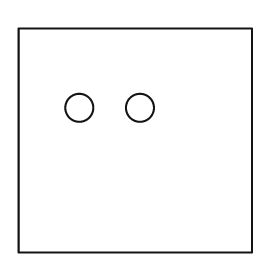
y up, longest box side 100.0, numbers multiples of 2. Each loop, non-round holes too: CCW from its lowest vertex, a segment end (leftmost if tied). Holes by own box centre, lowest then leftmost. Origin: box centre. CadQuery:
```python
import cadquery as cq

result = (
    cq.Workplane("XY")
    .moveTo(-50.0, -48.0)
    .lineTo(50.0, -48.0)
    .lineTo(50.0, 48.0)
    .lineTo(-50.0, 48.0)
    .close()
    .moveTo(-24.0, 14.0)
    .circle(6.0)
    .moveTo(2.0, 14.0)
    .circle(6.0)
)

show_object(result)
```